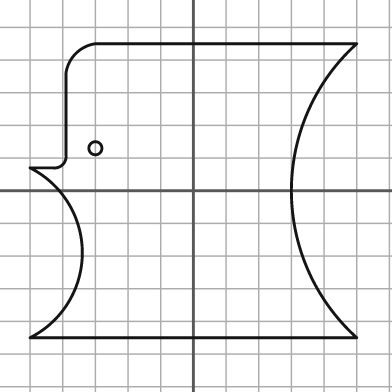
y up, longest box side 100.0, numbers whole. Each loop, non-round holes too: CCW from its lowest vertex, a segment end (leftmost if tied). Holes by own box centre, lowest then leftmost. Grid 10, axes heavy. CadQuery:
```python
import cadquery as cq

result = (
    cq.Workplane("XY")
    .moveTo(-50.0, -45.0)
    .lineTo(50.0, -45.0)
    .threePointArc((30.0, 0.0), (50.0, 45.0))
    .lineTo(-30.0, 45.0)
    .threePointArc((-36.0, 42.0), (-39.0, 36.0))
    .lineTo(-39.0, 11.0)
    .threePointArc((-40.0, 8.0), (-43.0, 7.0))
    .lineTo(-50.0, 7.0)
    .threePointArc((-34.0, -19.0), (-50.0, -45.0))
    .close()
    .moveTo(-30.0, 13.0)
    .circle(2.0)
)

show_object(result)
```